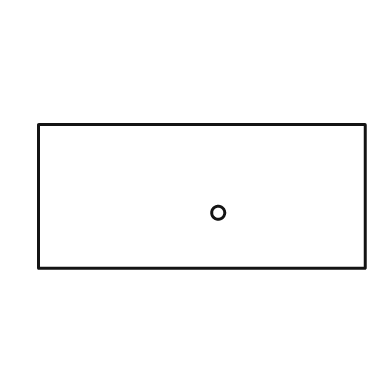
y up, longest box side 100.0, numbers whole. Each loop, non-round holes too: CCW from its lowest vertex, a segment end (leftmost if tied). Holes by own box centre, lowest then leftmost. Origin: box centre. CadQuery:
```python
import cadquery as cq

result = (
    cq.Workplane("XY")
    .moveTo(-50.0, -22.0)
    .lineTo(50.0, -22.0)
    .lineTo(50.0, 22.0)
    .lineTo(-50.0, 22.0)
    .close()
    .moveTo(5.0, -5.0)
    .circle(2.0)
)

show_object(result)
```